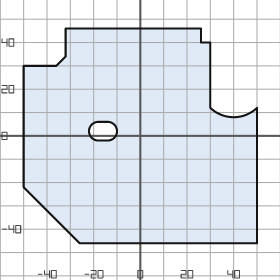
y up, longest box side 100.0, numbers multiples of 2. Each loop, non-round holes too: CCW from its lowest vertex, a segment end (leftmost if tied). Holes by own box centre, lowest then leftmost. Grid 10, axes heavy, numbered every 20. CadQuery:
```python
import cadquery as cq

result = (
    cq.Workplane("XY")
    .moveTo(-26.0, -46.0)
    .lineTo(50.0, -46.0)
    .lineTo(50.0, 12.0)
    .threePointArc((40.0, 8.0), (30.0, 12.0))
    .lineTo(30.0, 40.0)
    .lineTo(26.0, 40.0)
    .lineTo(26.0, 46.0)
    .lineTo(-32.0, 46.0)
    .lineTo(-32.0, 34.0)
    .lineTo(-36.0, 30.0)
    .lineTo(-50.0, 30.0)
    .lineTo(-50.0, -22.0)
    .close()
    .moveTo(-18.0, -2.0)
    .lineTo(-14.0, -2.0)
    .threePointArc((-10.0, 2.0), (-14.0, 6.0))
    .lineTo(-18.0, 6.0)
    .threePointArc((-22.0, 2.0), (-18.0, -2.0))
    .close()
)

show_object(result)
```